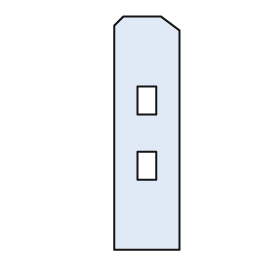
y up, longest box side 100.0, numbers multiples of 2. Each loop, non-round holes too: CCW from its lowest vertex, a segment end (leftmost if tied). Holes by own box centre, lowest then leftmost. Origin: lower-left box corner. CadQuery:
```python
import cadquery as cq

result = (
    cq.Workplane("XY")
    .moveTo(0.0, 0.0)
    .lineTo(28.0, 0.0)
    .lineTo(28.0, 94.0)
    .lineTo(20.0, 100.0)
    .lineTo(4.0, 100.0)
    .lineTo(0.0, 96.0)
    .close()
    .moveTo(10.0, 30.0)
    .lineTo(18.0, 30.0)
    .lineTo(18.0, 42.0)
    .lineTo(10.0, 42.0)
    .close()
    .moveTo(10.0, 58.0)
    .lineTo(18.0, 58.0)
    .lineTo(18.0, 70.0)
    .lineTo(10.0, 70.0)
    .close()
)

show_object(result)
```